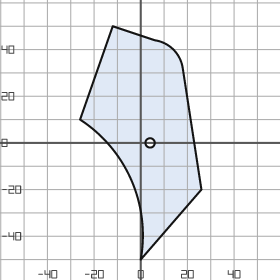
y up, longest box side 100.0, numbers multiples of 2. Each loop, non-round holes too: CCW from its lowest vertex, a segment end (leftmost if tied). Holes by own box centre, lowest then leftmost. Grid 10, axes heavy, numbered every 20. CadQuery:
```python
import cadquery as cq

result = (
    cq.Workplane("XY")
    .moveTo(0.0, -50.0)
    .lineTo(26.0, -20.0)
    .lineTo(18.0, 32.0)
    .threePointArc((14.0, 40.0), (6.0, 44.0))
    .lineTo(-12.0, 50.0)
    .lineTo(-26.0, 10.0)
    .threePointArc((-4.0, -16.0), (0.0, -50.0))
    .close()
    .moveTo(4.0, 0.0)
    .circle(2.0)
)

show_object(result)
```